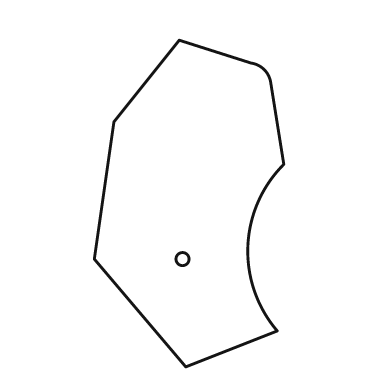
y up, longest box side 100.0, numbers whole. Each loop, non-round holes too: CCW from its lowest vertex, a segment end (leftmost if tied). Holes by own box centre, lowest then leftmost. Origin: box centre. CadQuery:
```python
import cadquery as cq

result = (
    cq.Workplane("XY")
    .moveTo(-1.0, -50.0)
    .lineTo(27.0, -39.0)
    .threePointArc((18.0, -13.0), (29.0, 12.0))
    .lineTo(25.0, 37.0)
    .threePointArc((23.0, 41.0), (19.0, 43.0))
    .lineTo(-3.0, 50.0)
    .lineTo(-23.0, 25.0)
    .lineTo(-29.0, -17.0)
    .close()
    .moveTo(-2.0, -17.0)
    .circle(2.0)
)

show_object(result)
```